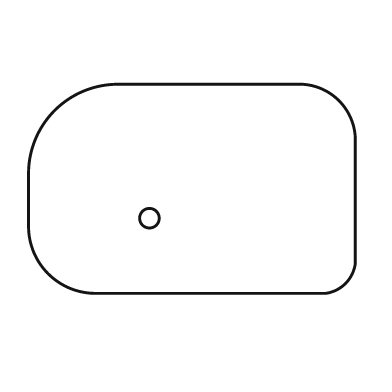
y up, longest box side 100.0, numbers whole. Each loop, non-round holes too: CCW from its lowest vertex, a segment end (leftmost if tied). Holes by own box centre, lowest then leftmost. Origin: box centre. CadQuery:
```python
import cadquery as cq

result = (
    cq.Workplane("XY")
    .moveTo(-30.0, -32.0)
    .lineTo(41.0, -32.0)
    .threePointArc((47.0, -29.0), (50.0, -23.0))
    .lineTo(50.0, 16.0)
    .threePointArc((45.0, 27.0), (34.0, 32.0))
    .lineTo(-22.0, 32.0)
    .threePointArc((-42.0, 24.0), (-50.0, 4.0))
    .lineTo(-50.0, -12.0)
    .threePointArc((-44.0, -26.0), (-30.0, -32.0))
    .close()
    .moveTo(-13.0, -9.0)
    .circle(3.0)
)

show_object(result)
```